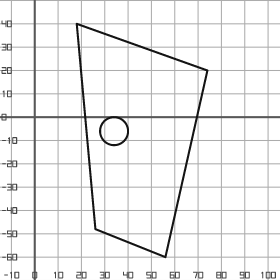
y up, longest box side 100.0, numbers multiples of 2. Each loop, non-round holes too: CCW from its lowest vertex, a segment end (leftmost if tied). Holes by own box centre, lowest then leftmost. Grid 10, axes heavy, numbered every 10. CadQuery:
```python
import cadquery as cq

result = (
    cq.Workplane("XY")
    .moveTo(56.0, -60.0)
    .lineTo(74.0, 20.0)
    .lineTo(18.0, 40.0)
    .lineTo(26.0, -48.0)
    .close()
    .moveTo(34.0, -6.0)
    .circle(6.0)
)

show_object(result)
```